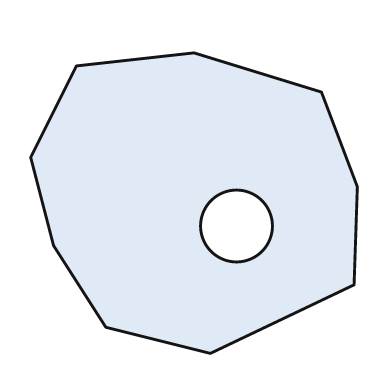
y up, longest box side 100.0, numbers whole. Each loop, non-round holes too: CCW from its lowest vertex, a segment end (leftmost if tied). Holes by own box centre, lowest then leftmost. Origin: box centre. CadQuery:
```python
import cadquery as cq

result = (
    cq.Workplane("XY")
    .moveTo(5.0, -46.0)
    .lineTo(49.0, -25.0)
    .lineTo(50.0, 5.0)
    .lineTo(39.0, 34.0)
    .lineTo(0.0, 46.0)
    .lineTo(-36.0, 42.0)
    .lineTo(-50.0, 14.0)
    .lineTo(-43.0, -13.0)
    .lineTo(-27.0, -38.0)
    .close()
    .moveTo(13.0, -7.0)
    .circle(11.0)
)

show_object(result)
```